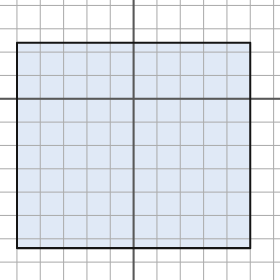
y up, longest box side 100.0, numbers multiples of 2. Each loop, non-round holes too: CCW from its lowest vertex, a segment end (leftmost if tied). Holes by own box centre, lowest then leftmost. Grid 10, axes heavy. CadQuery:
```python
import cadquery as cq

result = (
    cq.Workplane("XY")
    .moveTo(-50.0, -64.0)
    .lineTo(50.0, -64.0)
    .lineTo(50.0, 24.0)
    .lineTo(-50.0, 24.0)
    .close()
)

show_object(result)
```